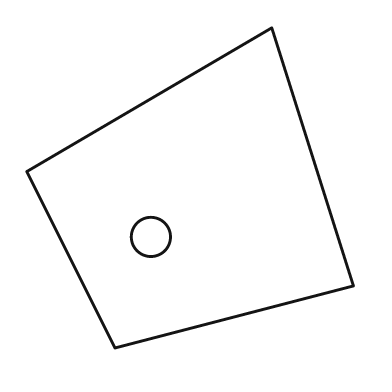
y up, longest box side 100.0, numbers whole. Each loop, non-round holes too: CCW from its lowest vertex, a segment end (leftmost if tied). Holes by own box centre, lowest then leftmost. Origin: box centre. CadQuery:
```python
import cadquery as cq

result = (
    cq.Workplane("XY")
    .moveTo(-23.0, -49.0)
    .lineTo(50.0, -30.0)
    .lineTo(25.0, 49.0)
    .lineTo(-50.0, 5.0)
    .close()
    .moveTo(-12.0, -15.0)
    .circle(6.0)
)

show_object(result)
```